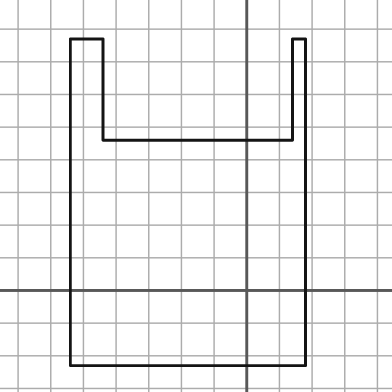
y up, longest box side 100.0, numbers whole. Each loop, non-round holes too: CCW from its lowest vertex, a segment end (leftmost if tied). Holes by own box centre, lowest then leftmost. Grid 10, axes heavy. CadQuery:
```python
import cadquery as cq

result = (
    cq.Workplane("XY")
    .moveTo(-54.0, -23.0)
    .lineTo(18.0, -23.0)
    .lineTo(18.0, 77.0)
    .lineTo(14.0, 77.0)
    .lineTo(14.0, 46.0)
    .lineTo(-44.0, 46.0)
    .lineTo(-44.0, 77.0)
    .lineTo(-54.0, 77.0)
    .close()
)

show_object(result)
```